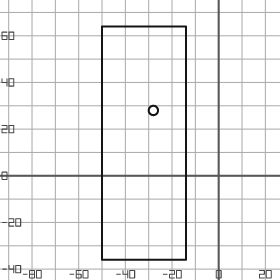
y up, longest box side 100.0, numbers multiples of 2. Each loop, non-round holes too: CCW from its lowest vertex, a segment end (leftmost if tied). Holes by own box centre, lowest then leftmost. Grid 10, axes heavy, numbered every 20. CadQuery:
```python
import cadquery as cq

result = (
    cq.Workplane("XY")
    .moveTo(-50.0, -36.0)
    .lineTo(-14.0, -36.0)
    .lineTo(-14.0, 64.0)
    .lineTo(-50.0, 64.0)
    .close()
    .moveTo(-28.0, 28.0)
    .circle(2.0)
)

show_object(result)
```